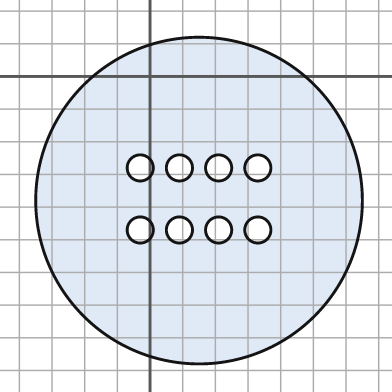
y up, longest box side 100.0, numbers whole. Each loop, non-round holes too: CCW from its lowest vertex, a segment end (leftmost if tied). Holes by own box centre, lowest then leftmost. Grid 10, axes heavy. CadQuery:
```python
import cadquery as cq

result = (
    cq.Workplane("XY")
    .moveTo(15.0, -38.0)
    .circle(50.0)
    .moveTo(-3.0, -47.0)
    .circle(4.0)
    .moveTo(9.0, -47.0)
    .circle(4.0)
    .moveTo(21.0, -47.0)
    .circle(4.0)
    .moveTo(33.0, -47.0)
    .circle(4.0)
    .moveTo(-3.0, -28.0)
    .circle(4.0)
    .moveTo(9.0, -28.0)
    .circle(4.0)
    .moveTo(21.0, -28.0)
    .circle(4.0)
    .moveTo(33.0, -28.0)
    .circle(4.0)
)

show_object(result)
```